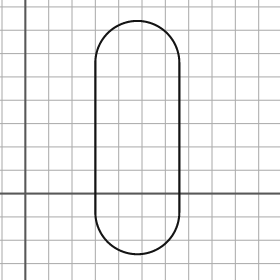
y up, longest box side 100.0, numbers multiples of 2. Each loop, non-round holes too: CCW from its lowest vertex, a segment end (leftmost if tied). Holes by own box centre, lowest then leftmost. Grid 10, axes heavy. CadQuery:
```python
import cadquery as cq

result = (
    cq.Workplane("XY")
    .moveTo(30.0, -8.0)
    .threePointArc((48.0, -26.0), (66.0, -8.0))
    .lineTo(66.0, 56.0)
    .threePointArc((48.0, 74.0), (30.0, 56.0))
    .close()
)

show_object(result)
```